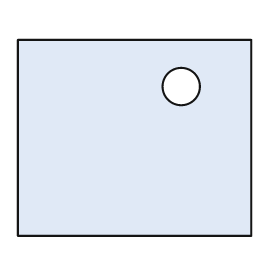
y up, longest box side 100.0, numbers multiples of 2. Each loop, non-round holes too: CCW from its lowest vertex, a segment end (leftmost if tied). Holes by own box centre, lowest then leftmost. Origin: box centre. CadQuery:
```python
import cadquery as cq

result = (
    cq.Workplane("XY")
    .moveTo(-50.0, -42.0)
    .lineTo(50.0, -42.0)
    .lineTo(50.0, 42.0)
    .lineTo(-50.0, 42.0)
    .close()
    .moveTo(20.0, 22.0)
    .circle(8.0)
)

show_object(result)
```